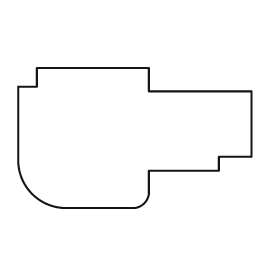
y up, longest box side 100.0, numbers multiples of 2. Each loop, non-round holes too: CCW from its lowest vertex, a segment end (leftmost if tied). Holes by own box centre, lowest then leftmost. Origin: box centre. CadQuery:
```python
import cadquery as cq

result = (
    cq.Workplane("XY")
    .moveTo(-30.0, -30.0)
    .lineTo(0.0, -30.0)
    .threePointArc((4.0, -28.0), (6.0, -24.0))
    .lineTo(6.0, -14.0)
    .lineTo(36.0, -14.0)
    .lineTo(36.0, -8.0)
    .lineTo(50.0, -8.0)
    .lineTo(50.0, 20.0)
    .lineTo(6.0, 20.0)
    .lineTo(6.0, 30.0)
    .lineTo(-42.0, 30.0)
    .lineTo(-42.0, 22.0)
    .lineTo(-50.0, 22.0)
    .lineTo(-50.0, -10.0)
    .threePointArc((-44.0, -24.0), (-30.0, -30.0))
    .close()
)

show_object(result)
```